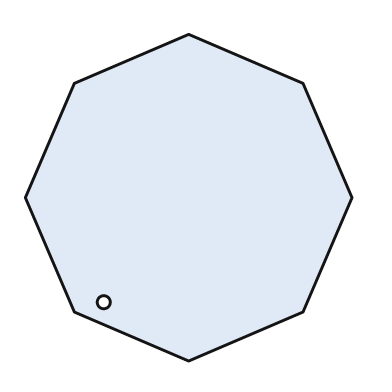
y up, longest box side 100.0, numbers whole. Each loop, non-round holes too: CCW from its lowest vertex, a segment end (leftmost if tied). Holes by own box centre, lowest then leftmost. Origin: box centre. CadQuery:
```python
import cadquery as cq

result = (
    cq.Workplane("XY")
    .moveTo(0.0, -50.0)
    .lineTo(35.0, -35.0)
    .lineTo(50.0, 0.0)
    .lineTo(35.0, 35.0)
    .lineTo(0.0, 50.0)
    .lineTo(-35.0, 35.0)
    .lineTo(-50.0, 0.0)
    .lineTo(-35.0, -35.0)
    .close()
    .moveTo(-26.0, -32.0)
    .circle(2.0)
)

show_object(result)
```